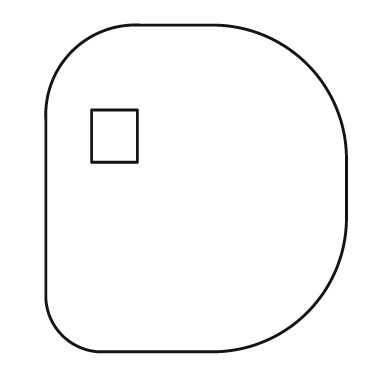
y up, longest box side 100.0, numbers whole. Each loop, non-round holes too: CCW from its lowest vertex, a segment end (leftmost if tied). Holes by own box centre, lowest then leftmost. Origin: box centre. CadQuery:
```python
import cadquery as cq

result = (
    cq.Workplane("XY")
    .moveTo(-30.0, -50.0)
    .lineTo(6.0, -50.0)
    .threePointArc((34.0, -38.0), (46.0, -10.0))
    .lineTo(46.0, 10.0)
    .threePointArc((34.0, 38.0), (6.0, 50.0))
    .lineTo(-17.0, 50.0)
    .threePointArc((-38.0, 42.0), (-46.0, 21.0))
    .lineTo(-46.0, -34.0)
    .threePointArc((-41.0, -45.0), (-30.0, -50.0))
    .close()
    .moveTo(-32.0, 8.0)
    .lineTo(-18.0, 8.0)
    .lineTo(-18.0, 24.0)
    .lineTo(-32.0, 24.0)
    .close()
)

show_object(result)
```